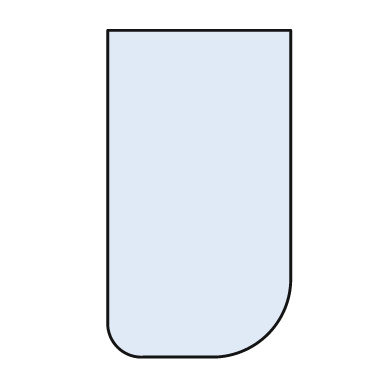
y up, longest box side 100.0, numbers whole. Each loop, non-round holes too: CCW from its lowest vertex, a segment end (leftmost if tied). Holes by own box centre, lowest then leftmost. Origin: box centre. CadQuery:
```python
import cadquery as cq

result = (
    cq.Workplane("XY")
    .moveTo(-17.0, -50.0)
    .lineTo(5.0, -50.0)
    .threePointArc((21.0, -43.0), (28.0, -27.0))
    .lineTo(28.0, 50.0)
    .lineTo(-28.0, 50.0)
    .lineTo(-28.0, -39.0)
    .threePointArc((-25.0, -47.0), (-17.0, -50.0))
    .close()
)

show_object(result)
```